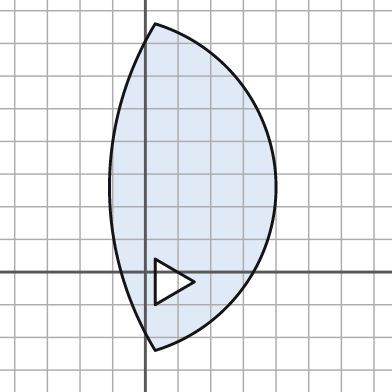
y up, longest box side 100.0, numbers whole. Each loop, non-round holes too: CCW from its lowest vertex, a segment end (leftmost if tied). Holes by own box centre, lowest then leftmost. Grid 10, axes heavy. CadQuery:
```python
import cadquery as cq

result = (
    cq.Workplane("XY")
    .moveTo(3.0, -24.0)
    .threePointArc((40.0, 26.0), (3.0, 76.0))
    .threePointArc((-11.0, 26.0), (3.0, -24.0))
    .close()
    .moveTo(3.0, -10.0)
    .lineTo(15.0, -3.0)
    .lineTo(3.0, 4.0)
    .close()
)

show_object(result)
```